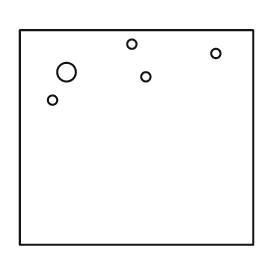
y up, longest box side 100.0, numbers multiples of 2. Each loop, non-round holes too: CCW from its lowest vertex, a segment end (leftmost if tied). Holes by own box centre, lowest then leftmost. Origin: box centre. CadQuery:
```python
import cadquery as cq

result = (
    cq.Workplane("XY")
    .moveTo(-50.0, -46.0)
    .lineTo(50.0, -46.0)
    .lineTo(50.0, 46.0)
    .lineTo(-50.0, 46.0)
    .close()
    .moveTo(-36.0, 16.0)
    .circle(2.0)
    .moveTo(4.0, 26.0)
    .circle(2.0)
    .moveTo(-30.0, 28.0)
    .circle(4.0)
    .moveTo(34.0, 36.0)
    .circle(2.0)
    .moveTo(-2.0, 40.0)
    .circle(2.0)
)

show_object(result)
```